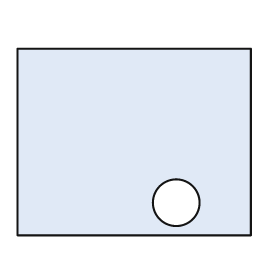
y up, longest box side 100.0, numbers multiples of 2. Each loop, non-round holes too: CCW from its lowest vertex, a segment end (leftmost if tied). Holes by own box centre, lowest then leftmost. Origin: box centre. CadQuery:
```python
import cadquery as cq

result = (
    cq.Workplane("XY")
    .moveTo(-50.0, -40.0)
    .lineTo(50.0, -40.0)
    .lineTo(50.0, 40.0)
    .lineTo(-50.0, 40.0)
    .close()
    .moveTo(18.0, -26.0)
    .circle(10.0)
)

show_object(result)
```